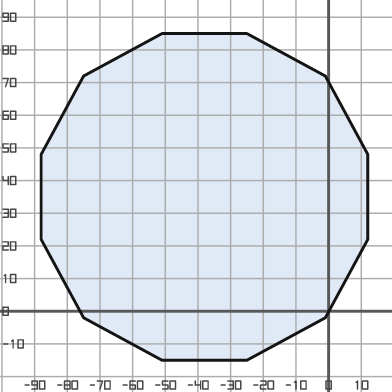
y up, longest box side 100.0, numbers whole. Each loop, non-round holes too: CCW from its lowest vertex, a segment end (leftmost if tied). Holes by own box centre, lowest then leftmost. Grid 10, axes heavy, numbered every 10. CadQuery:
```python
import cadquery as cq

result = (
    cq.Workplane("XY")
    .moveTo(-51.0, -15.0)
    .lineTo(-25.0, -15.0)
    .lineTo(-1.0, -2.0)
    .lineTo(12.0, 22.0)
    .lineTo(12.0, 48.0)
    .lineTo(-1.0, 72.0)
    .lineTo(-25.0, 85.0)
    .lineTo(-51.0, 85.0)
    .lineTo(-75.0, 72.0)
    .lineTo(-88.0, 48.0)
    .lineTo(-88.0, 22.0)
    .lineTo(-75.0, -2.0)
    .close()
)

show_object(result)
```